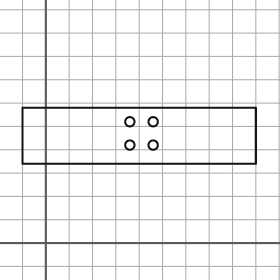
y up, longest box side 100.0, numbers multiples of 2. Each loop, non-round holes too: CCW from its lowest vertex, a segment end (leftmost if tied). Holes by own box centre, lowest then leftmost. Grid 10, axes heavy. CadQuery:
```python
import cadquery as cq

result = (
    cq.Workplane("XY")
    .moveTo(-10.0, 34.0)
    .lineTo(90.0, 34.0)
    .lineTo(90.0, 58.0)
    .lineTo(-10.0, 58.0)
    .close()
    .moveTo(36.0, 42.0)
    .circle(2.0)
    .moveTo(46.0, 42.0)
    .circle(2.0)
    .moveTo(36.0, 52.0)
    .circle(2.0)
    .moveTo(46.0, 52.0)
    .circle(2.0)
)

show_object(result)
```